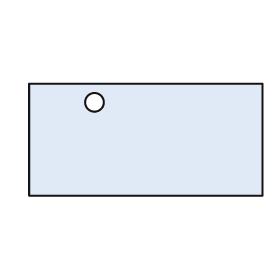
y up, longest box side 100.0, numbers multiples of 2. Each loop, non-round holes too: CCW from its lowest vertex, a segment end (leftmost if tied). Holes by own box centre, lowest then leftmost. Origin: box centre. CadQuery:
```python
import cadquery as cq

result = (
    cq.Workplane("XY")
    .moveTo(-50.0, -24.0)
    .lineTo(50.0, -24.0)
    .lineTo(50.0, 24.0)
    .lineTo(-50.0, 24.0)
    .close()
    .moveTo(-22.0, 16.0)
    .circle(4.0)
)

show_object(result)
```